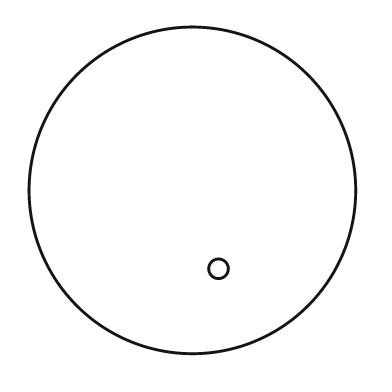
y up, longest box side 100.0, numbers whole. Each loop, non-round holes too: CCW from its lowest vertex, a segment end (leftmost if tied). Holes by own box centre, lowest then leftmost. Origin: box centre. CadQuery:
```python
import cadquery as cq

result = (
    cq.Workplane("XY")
    .moveTo(0.0, 0.0)
    .circle(50.0)
    .moveTo(8.0, -24.0)
    .circle(3.0)
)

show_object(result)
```